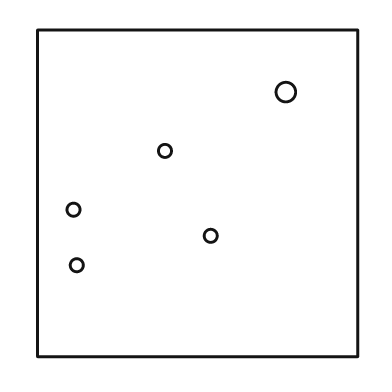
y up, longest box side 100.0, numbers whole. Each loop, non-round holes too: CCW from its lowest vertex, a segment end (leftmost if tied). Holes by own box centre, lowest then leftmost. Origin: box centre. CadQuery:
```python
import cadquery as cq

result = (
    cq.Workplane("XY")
    .moveTo(-49.0, -50.0)
    .lineTo(49.0, -50.0)
    .lineTo(49.0, 50.0)
    .lineTo(-49.0, 50.0)
    .close()
    .moveTo(-37.0, -22.0)
    .circle(2.0)
    .moveTo(4.0, -13.0)
    .circle(2.0)
    .moveTo(-38.0, -5.0)
    .circle(2.0)
    .moveTo(-10.0, 13.0)
    .circle(2.0)
    .moveTo(27.0, 31.0)
    .circle(3.0)
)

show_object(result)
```